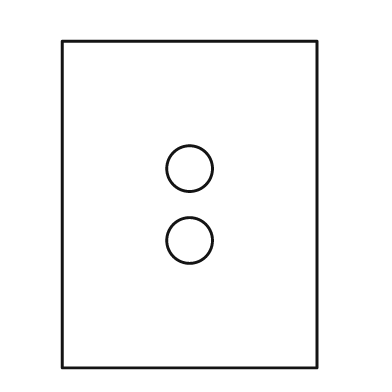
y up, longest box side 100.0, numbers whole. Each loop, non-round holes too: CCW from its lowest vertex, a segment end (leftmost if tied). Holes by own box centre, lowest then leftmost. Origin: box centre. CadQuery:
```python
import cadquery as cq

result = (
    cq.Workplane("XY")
    .moveTo(-39.0, -50.0)
    .lineTo(39.0, -50.0)
    .lineTo(39.0, 50.0)
    .lineTo(-39.0, 50.0)
    .close()
    .moveTo(0.0, -11.0)
    .circle(7.0)
    .moveTo(0.0, 11.0)
    .circle(7.0)
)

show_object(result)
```